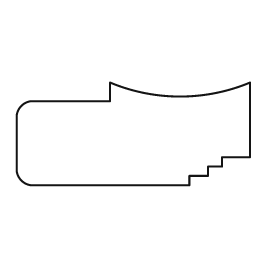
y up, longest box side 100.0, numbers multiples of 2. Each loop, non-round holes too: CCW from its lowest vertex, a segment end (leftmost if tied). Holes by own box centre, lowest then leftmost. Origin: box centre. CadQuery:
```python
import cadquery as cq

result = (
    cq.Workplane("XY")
    .moveTo(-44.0, -22.0)
    .lineTo(24.0, -22.0)
    .lineTo(24.0, -18.0)
    .lineTo(32.0, -18.0)
    .lineTo(32.0, -14.0)
    .lineTo(38.0, -14.0)
    .lineTo(38.0, -10.0)
    .lineTo(50.0, -10.0)
    .lineTo(50.0, 22.0)
    .threePointArc((20.0, 16.0), (-10.0, 22.0))
    .lineTo(-10.0, 14.0)
    .lineTo(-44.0, 14.0)
    .threePointArc((-48.0, 12.0), (-50.0, 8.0))
    .lineTo(-50.0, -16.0)
    .threePointArc((-48.0, -20.0), (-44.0, -22.0))
    .close()
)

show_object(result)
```